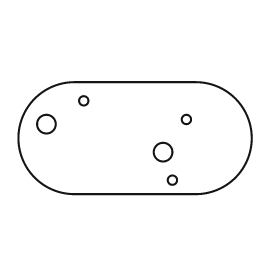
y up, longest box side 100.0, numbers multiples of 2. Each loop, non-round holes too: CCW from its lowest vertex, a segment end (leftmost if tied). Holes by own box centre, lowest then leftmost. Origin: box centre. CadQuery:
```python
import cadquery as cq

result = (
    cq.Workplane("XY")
    .moveTo(-26.0, -24.0)
    .lineTo(26.0, -24.0)
    .threePointArc((50.0, 0.0), (26.0, 24.0))
    .lineTo(-26.0, 24.0)
    .threePointArc((-50.0, 0.0), (-26.0, -24.0))
    .close()
    .moveTo(16.0, -18.0)
    .circle(2.0)
    .moveTo(12.0, -6.0)
    .circle(4.0)
    .moveTo(-38.0, 6.0)
    .circle(4.0)
    .moveTo(22.0, 8.0)
    .circle(2.0)
    .moveTo(-22.0, 16.0)
    .circle(2.0)
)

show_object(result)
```